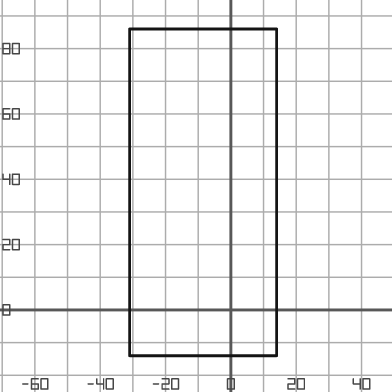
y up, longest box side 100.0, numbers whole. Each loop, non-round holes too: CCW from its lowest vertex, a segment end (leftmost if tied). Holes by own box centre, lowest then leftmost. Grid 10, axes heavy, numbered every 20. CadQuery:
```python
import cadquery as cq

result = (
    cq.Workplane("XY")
    .moveTo(-31.0, -14.0)
    .lineTo(14.0, -14.0)
    .lineTo(14.0, 86.0)
    .lineTo(-31.0, 86.0)
    .close()
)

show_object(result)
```